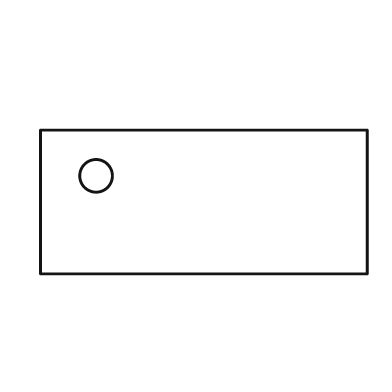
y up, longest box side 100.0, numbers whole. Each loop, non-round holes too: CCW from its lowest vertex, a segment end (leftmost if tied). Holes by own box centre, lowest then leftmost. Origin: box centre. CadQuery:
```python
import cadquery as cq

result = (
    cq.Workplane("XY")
    .moveTo(-50.0, -22.0)
    .lineTo(50.0, -22.0)
    .lineTo(50.0, 22.0)
    .lineTo(-50.0, 22.0)
    .close()
    .moveTo(-33.0, 8.0)
    .circle(5.0)
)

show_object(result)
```